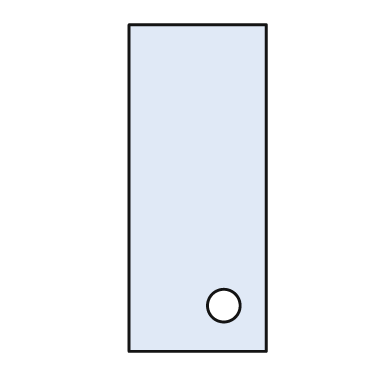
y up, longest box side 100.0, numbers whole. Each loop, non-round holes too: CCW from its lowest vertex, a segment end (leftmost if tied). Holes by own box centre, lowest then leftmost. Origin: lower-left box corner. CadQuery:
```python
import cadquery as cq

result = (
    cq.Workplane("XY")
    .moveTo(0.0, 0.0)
    .lineTo(42.0, 0.0)
    .lineTo(42.0, 100.0)
    .lineTo(0.0, 100.0)
    .close()
    .moveTo(29.0, 14.0)
    .circle(5.0)
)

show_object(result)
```